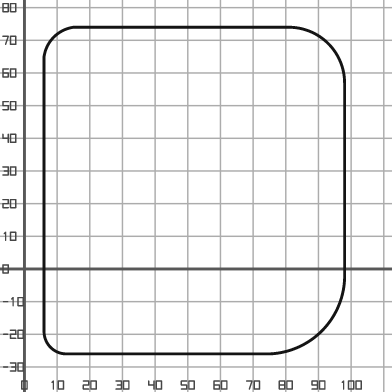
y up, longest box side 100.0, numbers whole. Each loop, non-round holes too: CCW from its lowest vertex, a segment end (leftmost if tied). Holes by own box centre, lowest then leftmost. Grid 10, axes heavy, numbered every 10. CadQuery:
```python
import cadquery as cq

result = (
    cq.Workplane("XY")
    .moveTo(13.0, -26.0)
    .lineTo(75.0, -26.0)
    .threePointArc((91.0, -19.0), (98.0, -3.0))
    .lineTo(98.0, 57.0)
    .threePointArc((93.0, 69.0), (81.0, 74.0))
    .lineTo(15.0, 74.0)
    .threePointArc((9.0, 71.0), (6.0, 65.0))
    .lineTo(6.0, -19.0)
    .threePointArc((8.0, -24.0), (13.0, -26.0))
    .close()
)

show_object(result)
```